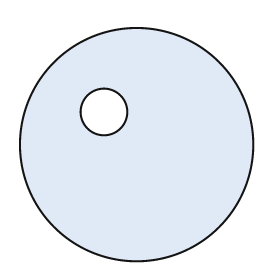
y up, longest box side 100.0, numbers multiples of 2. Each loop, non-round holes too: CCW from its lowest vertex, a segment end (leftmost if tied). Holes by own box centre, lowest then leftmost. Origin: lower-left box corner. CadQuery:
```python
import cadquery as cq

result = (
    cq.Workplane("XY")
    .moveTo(50.0, 50.0)
    .circle(50.0)
    .moveTo(36.0, 64.0)
    .circle(10.0)
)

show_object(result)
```